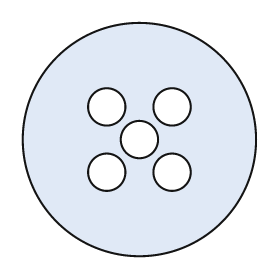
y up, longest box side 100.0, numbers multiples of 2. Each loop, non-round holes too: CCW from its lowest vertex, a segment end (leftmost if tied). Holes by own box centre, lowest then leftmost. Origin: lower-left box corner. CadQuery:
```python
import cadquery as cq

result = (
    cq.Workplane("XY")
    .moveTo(50.0, 50.0)
    .circle(50.0)
    .moveTo(36.0, 36.0)
    .circle(8.0)
    .moveTo(64.0, 36.0)
    .circle(8.0)
    .moveTo(50.0, 50.0)
    .circle(8.0)
    .moveTo(36.0, 64.0)
    .circle(8.0)
    .moveTo(64.0, 64.0)
    .circle(8.0)
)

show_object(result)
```